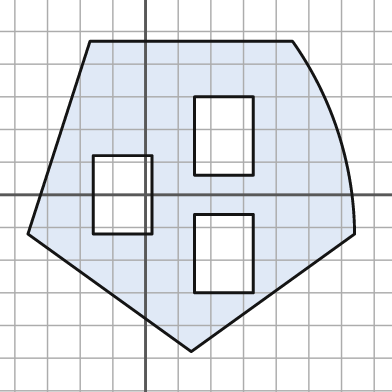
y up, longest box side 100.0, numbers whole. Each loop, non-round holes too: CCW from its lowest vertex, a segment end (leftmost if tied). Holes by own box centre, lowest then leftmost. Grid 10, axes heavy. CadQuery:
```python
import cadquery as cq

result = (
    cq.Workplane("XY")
    .moveTo(14.0, -48.0)
    .lineTo(64.0, -12.0)
    .threePointArc((59.0, 19.0), (45.0, 47.0))
    .lineTo(-17.0, 47.0)
    .lineTo(-36.0, -12.0)
    .close()
    .moveTo(15.0, -30.0)
    .lineTo(33.0, -30.0)
    .lineTo(33.0, -6.0)
    .lineTo(15.0, -6.0)
    .close()
    .moveTo(-16.0, -12.0)
    .lineTo(2.0, -12.0)
    .lineTo(2.0, 12.0)
    .lineTo(-16.0, 12.0)
    .close()
    .moveTo(15.0, 6.0)
    .lineTo(33.0, 6.0)
    .lineTo(33.0, 30.0)
    .lineTo(15.0, 30.0)
    .close()
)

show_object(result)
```